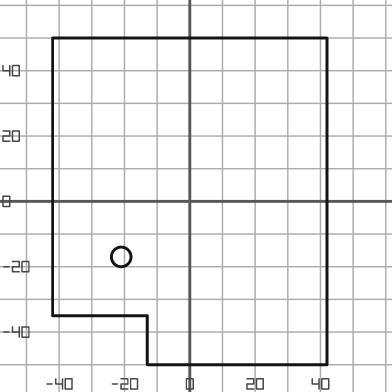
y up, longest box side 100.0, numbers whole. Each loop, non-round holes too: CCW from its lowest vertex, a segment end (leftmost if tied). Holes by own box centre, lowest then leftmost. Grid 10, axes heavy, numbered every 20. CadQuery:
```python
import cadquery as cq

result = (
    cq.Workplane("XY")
    .moveTo(-13.0, -50.0)
    .lineTo(42.0, -50.0)
    .lineTo(42.0, 50.0)
    .lineTo(-42.0, 50.0)
    .lineTo(-42.0, -35.0)
    .lineTo(-13.0, -35.0)
    .close()
    .moveTo(-21.0, -17.0)
    .circle(3.0)
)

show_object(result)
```